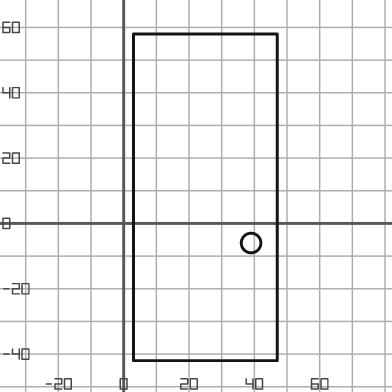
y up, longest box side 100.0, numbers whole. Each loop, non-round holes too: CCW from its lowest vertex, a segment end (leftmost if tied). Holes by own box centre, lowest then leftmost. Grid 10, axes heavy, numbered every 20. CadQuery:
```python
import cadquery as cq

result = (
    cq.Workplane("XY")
    .moveTo(3.0, -42.0)
    .lineTo(47.0, -42.0)
    .lineTo(47.0, 58.0)
    .lineTo(3.0, 58.0)
    .close()
    .moveTo(39.0, -6.0)
    .circle(3.0)
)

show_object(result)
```